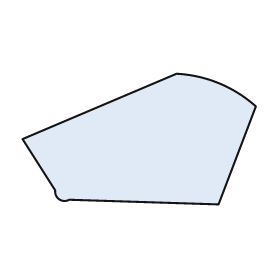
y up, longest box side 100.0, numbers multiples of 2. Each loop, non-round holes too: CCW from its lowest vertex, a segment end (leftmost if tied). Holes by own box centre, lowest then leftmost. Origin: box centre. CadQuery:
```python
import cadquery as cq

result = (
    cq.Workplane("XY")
    .moveTo(34.0, -28.0)
    .lineTo(50.0, 14.0)
    .threePointArc((34.0, 24.0), (16.0, 28.0))
    .lineTo(-50.0, 0.0)
    .lineTo(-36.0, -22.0)
    .threePointArc((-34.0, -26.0), (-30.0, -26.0))
    .close()
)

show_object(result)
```